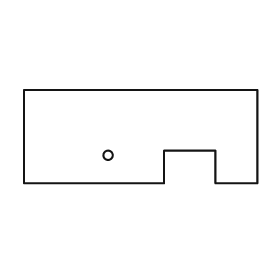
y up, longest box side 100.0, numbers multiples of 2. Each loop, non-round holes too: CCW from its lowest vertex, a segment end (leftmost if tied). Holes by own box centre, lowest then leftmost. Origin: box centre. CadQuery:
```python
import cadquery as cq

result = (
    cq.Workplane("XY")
    .moveTo(-50.0, -20.0)
    .lineTo(10.0, -20.0)
    .lineTo(10.0, -6.0)
    .lineTo(32.0, -6.0)
    .lineTo(32.0, -20.0)
    .lineTo(50.0, -20.0)
    .lineTo(50.0, 20.0)
    .lineTo(-50.0, 20.0)
    .close()
    .moveTo(-14.0, -8.0)
    .circle(2.0)
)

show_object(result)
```